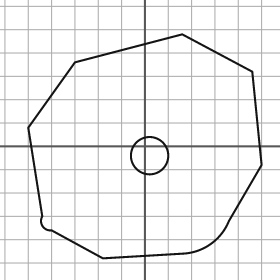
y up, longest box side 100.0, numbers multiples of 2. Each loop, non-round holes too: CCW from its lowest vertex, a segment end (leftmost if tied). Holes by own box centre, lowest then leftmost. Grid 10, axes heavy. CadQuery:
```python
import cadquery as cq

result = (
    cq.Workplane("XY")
    .moveTo(-18.0, -48.0)
    .lineTo(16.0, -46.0)
    .threePointArc((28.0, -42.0), (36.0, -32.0))
    .lineTo(50.0, -8.0)
    .lineTo(46.0, 32.0)
    .lineTo(16.0, 48.0)
    .lineTo(-30.0, 36.0)
    .lineTo(-50.0, 8.0)
    .lineTo(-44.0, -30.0)
    .threePointArc((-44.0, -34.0), (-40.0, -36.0))
    .close()
    .moveTo(2.0, -4.0)
    .circle(8.0)
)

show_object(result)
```